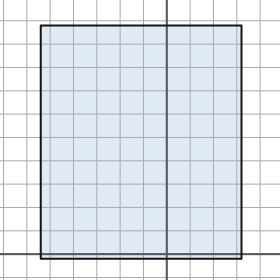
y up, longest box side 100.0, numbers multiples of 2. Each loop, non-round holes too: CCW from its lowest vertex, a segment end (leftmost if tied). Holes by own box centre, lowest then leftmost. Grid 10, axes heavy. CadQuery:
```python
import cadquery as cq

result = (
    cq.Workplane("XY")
    .moveTo(-54.0, -2.0)
    .lineTo(32.0, -2.0)
    .lineTo(32.0, 98.0)
    .lineTo(-54.0, 98.0)
    .close()
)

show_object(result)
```